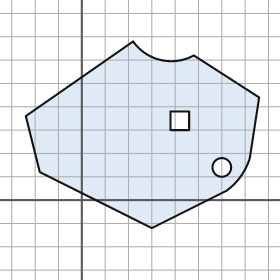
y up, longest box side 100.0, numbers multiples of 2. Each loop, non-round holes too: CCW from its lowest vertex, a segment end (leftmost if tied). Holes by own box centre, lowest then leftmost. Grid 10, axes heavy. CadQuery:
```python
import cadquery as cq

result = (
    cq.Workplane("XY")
    .moveTo(30.0, -12.0)
    .lineTo(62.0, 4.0)
    .threePointArc((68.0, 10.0), (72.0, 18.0))
    .lineTo(76.0, 44.0)
    .lineTo(48.0, 62.0)
    .threePointArc((34.0, 60.0), (22.0, 68.0))
    .lineTo(-24.0, 36.0)
    .lineTo(-18.0, 12.0)
    .close()
    .moveTo(60.0, 14.0)
    .circle(4.0)
    .moveTo(38.0, 30.0)
    .lineTo(46.0, 30.0)
    .lineTo(46.0, 38.0)
    .lineTo(38.0, 38.0)
    .close()
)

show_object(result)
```